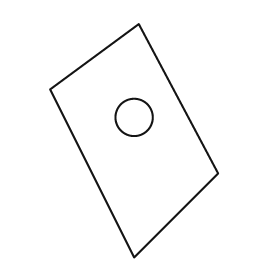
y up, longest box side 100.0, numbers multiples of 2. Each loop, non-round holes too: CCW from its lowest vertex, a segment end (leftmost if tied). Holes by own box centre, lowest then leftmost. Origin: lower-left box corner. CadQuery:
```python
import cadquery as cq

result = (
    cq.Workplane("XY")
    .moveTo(36.0, 0.0)
    .lineTo(72.0, 36.0)
    .lineTo(38.0, 100.0)
    .lineTo(0.0, 72.0)
    .close()
    .moveTo(36.0, 60.0)
    .circle(8.0)
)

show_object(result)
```